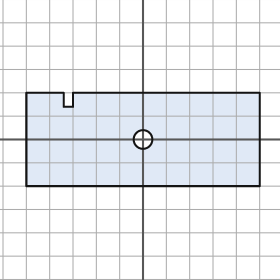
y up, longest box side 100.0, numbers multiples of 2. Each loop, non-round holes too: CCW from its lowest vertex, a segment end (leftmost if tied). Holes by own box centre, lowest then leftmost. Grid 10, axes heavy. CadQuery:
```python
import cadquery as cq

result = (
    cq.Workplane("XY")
    .moveTo(-50.0, -20.0)
    .lineTo(50.0, -20.0)
    .lineTo(50.0, 20.0)
    .lineTo(-30.0, 20.0)
    .lineTo(-30.0, 14.0)
    .lineTo(-34.0, 14.0)
    .lineTo(-34.0, 20.0)
    .lineTo(-50.0, 20.0)
    .close()
    .moveTo(0.0, 0.0)
    .circle(4.0)
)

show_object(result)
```